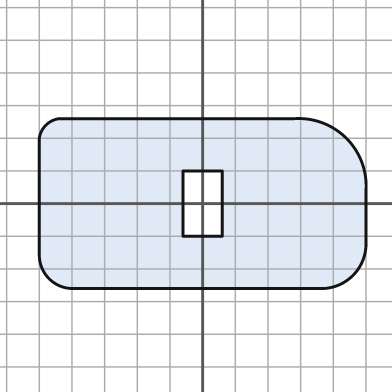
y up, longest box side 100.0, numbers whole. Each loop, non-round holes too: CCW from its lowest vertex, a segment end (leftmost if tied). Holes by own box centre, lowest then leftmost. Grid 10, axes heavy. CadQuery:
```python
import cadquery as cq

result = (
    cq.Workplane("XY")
    .moveTo(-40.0, -26.0)
    .lineTo(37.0, -26.0)
    .threePointArc((46.0, -22.0), (50.0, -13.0))
    .lineTo(50.0, 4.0)
    .threePointArc((44.0, 20.0), (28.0, 26.0))
    .lineTo(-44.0, 26.0)
    .threePointArc((-48.0, 24.0), (-50.0, 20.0))
    .lineTo(-50.0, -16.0)
    .threePointArc((-47.0, -23.0), (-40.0, -26.0))
    .close()
    .moveTo(-6.0, -10.0)
    .lineTo(6.0, -10.0)
    .lineTo(6.0, 10.0)
    .lineTo(-6.0, 10.0)
    .close()
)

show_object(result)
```